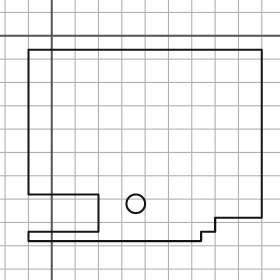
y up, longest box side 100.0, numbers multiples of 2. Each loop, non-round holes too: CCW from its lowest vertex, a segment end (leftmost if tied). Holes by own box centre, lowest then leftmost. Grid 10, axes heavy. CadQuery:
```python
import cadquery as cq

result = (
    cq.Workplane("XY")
    .moveTo(-10.0, -88.0)
    .lineTo(64.0, -88.0)
    .lineTo(64.0, -84.0)
    .lineTo(70.0, -84.0)
    .lineTo(70.0, -78.0)
    .lineTo(90.0, -78.0)
    .lineTo(90.0, -6.0)
    .lineTo(-10.0, -6.0)
    .lineTo(-10.0, -68.0)
    .lineTo(20.0, -68.0)
    .lineTo(20.0, -84.0)
    .lineTo(-10.0, -84.0)
    .close()
    .moveTo(36.0, -72.0)
    .circle(4.0)
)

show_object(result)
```